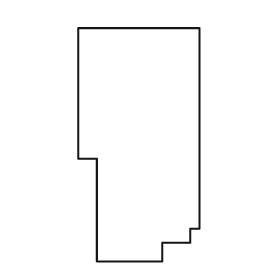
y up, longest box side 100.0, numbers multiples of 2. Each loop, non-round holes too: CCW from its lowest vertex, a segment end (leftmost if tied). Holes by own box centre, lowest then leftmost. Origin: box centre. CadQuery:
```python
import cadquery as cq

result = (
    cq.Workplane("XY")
    .moveTo(-18.0, -50.0)
    .lineTo(10.0, -50.0)
    .lineTo(10.0, -42.0)
    .lineTo(22.0, -42.0)
    .lineTo(22.0, -36.0)
    .lineTo(26.0, -36.0)
    .lineTo(26.0, 50.0)
    .lineTo(-26.0, 50.0)
    .lineTo(-26.0, -6.0)
    .lineTo(-18.0, -6.0)
    .close()
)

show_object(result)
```